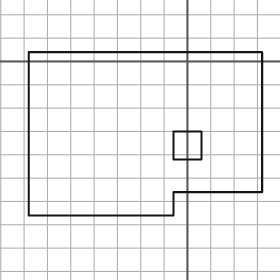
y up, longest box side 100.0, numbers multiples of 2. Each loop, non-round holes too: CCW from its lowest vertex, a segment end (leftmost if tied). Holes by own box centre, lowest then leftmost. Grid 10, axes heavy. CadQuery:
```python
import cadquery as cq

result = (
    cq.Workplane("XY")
    .moveTo(-68.0, -66.0)
    .lineTo(-6.0, -66.0)
    .lineTo(-6.0, -56.0)
    .lineTo(32.0, -56.0)
    .lineTo(32.0, 4.0)
    .lineTo(-68.0, 4.0)
    .close()
    .moveTo(-6.0, -42.0)
    .lineTo(6.0, -42.0)
    .lineTo(6.0, -30.0)
    .lineTo(-6.0, -30.0)
    .close()
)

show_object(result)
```